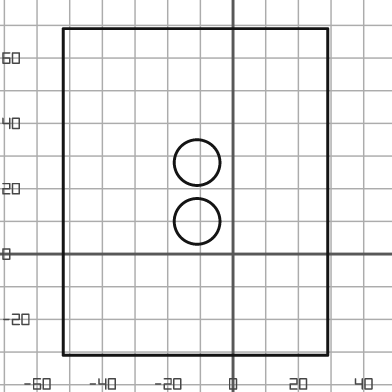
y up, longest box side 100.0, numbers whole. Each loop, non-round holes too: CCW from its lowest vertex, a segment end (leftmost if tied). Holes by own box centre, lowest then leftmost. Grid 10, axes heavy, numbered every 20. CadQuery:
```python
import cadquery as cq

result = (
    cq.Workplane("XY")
    .moveTo(-52.0, -31.0)
    .lineTo(29.0, -31.0)
    .lineTo(29.0, 69.0)
    .lineTo(-52.0, 69.0)
    .close()
    .moveTo(-11.0, 10.0)
    .circle(7.0)
    .moveTo(-11.0, 28.0)
    .circle(7.0)
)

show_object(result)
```